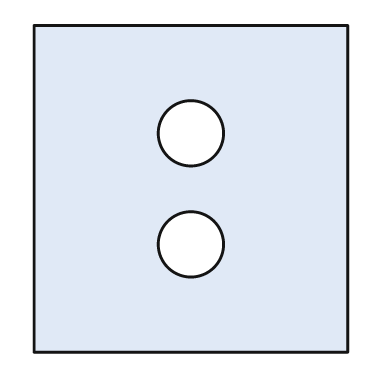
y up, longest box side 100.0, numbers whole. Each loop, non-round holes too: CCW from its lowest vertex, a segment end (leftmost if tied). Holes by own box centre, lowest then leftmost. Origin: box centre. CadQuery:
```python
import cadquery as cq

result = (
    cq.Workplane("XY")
    .moveTo(-48.0, -50.0)
    .lineTo(48.0, -50.0)
    .lineTo(48.0, 50.0)
    .lineTo(-48.0, 50.0)
    .close()
    .moveTo(0.0, -17.0)
    .circle(10.0)
    .moveTo(0.0, 17.0)
    .circle(10.0)
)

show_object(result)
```